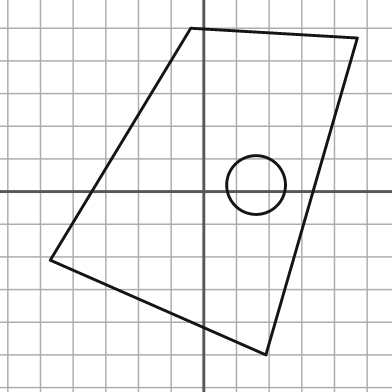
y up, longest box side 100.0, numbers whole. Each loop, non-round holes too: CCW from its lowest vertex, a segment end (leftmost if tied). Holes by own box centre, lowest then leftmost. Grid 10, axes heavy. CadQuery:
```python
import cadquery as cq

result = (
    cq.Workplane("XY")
    .moveTo(19.0, -50.0)
    .lineTo(47.0, 47.0)
    .lineTo(-4.0, 50.0)
    .lineTo(-47.0, -21.0)
    .close()
    .moveTo(16.0, 2.0)
    .circle(9.0)
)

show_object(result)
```